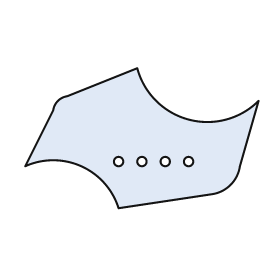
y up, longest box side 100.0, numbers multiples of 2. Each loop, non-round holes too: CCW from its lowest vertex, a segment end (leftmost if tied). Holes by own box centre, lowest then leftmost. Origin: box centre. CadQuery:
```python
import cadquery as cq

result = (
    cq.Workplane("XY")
    .moveTo(-10.0, -30.0)
    .lineTo(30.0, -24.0)
    .threePointArc((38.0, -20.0), (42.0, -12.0))
    .lineTo(50.0, 16.0)
    .threePointArc((20.0, 8.0), (-2.0, 30.0))
    .lineTo(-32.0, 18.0)
    .threePointArc((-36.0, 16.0), (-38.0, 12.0))
    .lineTo(-50.0, -12.0)
    .threePointArc((-26.0, -12.0), (-10.0, -30.0))
    .close()
    .moveTo(-10.0, -10.0)
    .circle(2.0)
    .moveTo(0.0, -10.0)
    .circle(2.0)
    .moveTo(10.0, -10.0)
    .circle(2.0)
    .moveTo(20.0, -10.0)
    .circle(2.0)
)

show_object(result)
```